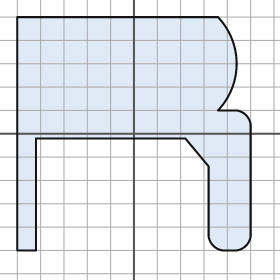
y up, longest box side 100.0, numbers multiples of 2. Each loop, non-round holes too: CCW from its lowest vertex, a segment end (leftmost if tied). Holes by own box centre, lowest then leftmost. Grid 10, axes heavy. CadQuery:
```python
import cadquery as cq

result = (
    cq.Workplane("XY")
    .moveTo(-50.0, -50.0)
    .lineTo(-42.0, -50.0)
    .lineTo(-42.0, -2.0)
    .lineTo(22.0, -2.0)
    .lineTo(32.0, -14.0)
    .lineTo(32.0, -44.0)
    .threePointArc((34.0, -48.0), (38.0, -50.0))
    .lineTo(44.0, -50.0)
    .threePointArc((48.0, -48.0), (50.0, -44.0))
    .lineTo(50.0, 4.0)
    .threePointArc((48.0, 8.0), (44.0, 10.0))
    .lineTo(36.0, 10.0)
    .threePointArc((44.0, 30.0), (36.0, 50.0))
    .lineTo(-50.0, 50.0)
    .close()
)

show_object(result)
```